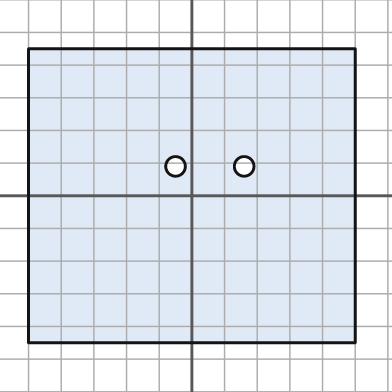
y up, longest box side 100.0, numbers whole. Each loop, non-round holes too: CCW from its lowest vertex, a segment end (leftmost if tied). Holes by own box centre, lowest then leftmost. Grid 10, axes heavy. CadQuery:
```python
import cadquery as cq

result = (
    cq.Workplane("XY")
    .moveTo(-50.0, -45.0)
    .lineTo(50.0, -45.0)
    .lineTo(50.0, 45.0)
    .lineTo(-50.0, 45.0)
    .close()
    .moveTo(-5.0, 9.0)
    .circle(3.0)
    .moveTo(16.0, 9.0)
    .circle(3.0)
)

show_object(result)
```